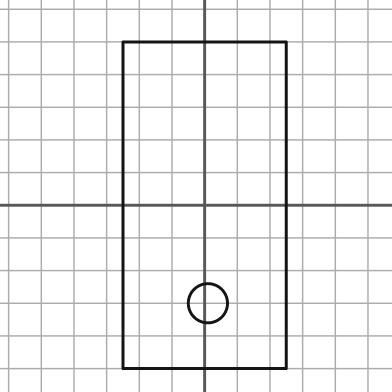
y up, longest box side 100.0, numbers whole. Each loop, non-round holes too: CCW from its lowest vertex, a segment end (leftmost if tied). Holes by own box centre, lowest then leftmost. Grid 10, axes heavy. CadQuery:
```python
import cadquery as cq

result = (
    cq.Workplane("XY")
    .moveTo(-25.0, -50.0)
    .lineTo(25.0, -50.0)
    .lineTo(25.0, 50.0)
    .lineTo(-25.0, 50.0)
    .close()
    .moveTo(1.0, -30.0)
    .circle(6.0)
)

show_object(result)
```